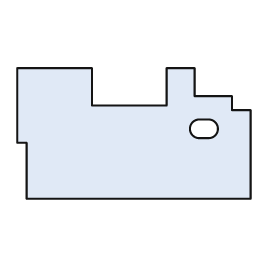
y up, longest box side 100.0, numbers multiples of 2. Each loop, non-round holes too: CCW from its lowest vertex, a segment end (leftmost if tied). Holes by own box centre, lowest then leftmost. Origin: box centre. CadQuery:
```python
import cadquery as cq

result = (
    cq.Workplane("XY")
    .moveTo(-46.0, -28.0)
    .lineTo(50.0, -28.0)
    .lineTo(50.0, 10.0)
    .lineTo(42.0, 10.0)
    .lineTo(42.0, 16.0)
    .lineTo(26.0, 16.0)
    .lineTo(26.0, 28.0)
    .lineTo(14.0, 28.0)
    .lineTo(14.0, 12.0)
    .lineTo(-18.0, 12.0)
    .lineTo(-18.0, 28.0)
    .lineTo(-50.0, 28.0)
    .lineTo(-50.0, -4.0)
    .lineTo(-46.0, -4.0)
    .close()
    .moveTo(28.0, -2.0)
    .lineTo(32.0, -2.0)
    .threePointArc((36.0, 2.0), (32.0, 6.0))
    .lineTo(28.0, 6.0)
    .threePointArc((24.0, 2.0), (28.0, -2.0))
    .close()
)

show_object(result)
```